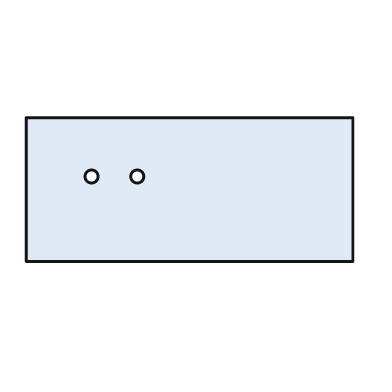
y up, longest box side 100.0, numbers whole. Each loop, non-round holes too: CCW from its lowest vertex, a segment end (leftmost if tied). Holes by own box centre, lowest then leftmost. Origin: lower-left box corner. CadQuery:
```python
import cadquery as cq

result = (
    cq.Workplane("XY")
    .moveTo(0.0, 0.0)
    .lineTo(100.0, 0.0)
    .lineTo(100.0, 44.0)
    .lineTo(0.0, 44.0)
    .close()
    .moveTo(20.0, 26.0)
    .circle(2.0)
    .moveTo(34.0, 26.0)
    .circle(2.0)
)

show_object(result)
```